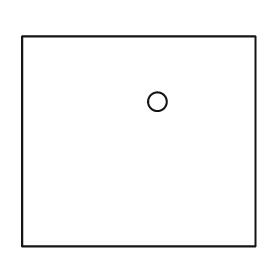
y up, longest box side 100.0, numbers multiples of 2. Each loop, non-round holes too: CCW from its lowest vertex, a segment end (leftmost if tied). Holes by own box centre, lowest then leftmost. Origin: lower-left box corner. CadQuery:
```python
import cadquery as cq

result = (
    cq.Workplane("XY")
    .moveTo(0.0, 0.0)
    .lineTo(100.0, 0.0)
    .lineTo(100.0, 90.0)
    .lineTo(0.0, 90.0)
    .close()
    .moveTo(58.0, 62.0)
    .circle(4.0)
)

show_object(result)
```